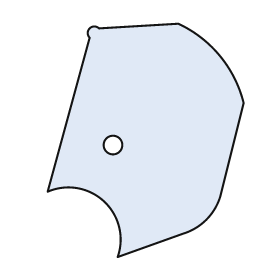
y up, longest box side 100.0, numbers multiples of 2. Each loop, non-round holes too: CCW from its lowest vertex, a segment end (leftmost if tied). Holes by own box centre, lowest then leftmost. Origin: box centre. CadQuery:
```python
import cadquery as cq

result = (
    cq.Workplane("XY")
    .moveTo(-12.0, -50.0)
    .lineTo(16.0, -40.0)
    .threePointArc((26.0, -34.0), (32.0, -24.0))
    .lineTo(42.0, 16.0)
    .threePointArc((32.0, 36.0), (14.0, 50.0))
    .lineTo(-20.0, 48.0)
    .threePointArc((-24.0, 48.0), (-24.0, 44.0))
    .lineTo(-42.0, -22.0)
    .threePointArc((-18.0, -26.0), (-12.0, -50.0))
    .close()
    .moveTo(-14.0, -2.0)
    .circle(4.0)
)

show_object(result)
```